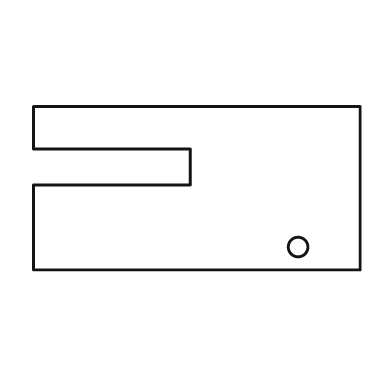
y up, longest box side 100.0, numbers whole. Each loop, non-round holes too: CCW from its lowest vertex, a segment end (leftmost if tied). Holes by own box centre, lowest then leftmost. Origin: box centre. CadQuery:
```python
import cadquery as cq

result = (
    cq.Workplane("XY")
    .moveTo(-50.0, -25.0)
    .lineTo(50.0, -25.0)
    .lineTo(50.0, 25.0)
    .lineTo(-50.0, 25.0)
    .lineTo(-50.0, 12.0)
    .lineTo(-2.0, 12.0)
    .lineTo(-2.0, 1.0)
    .lineTo(-50.0, 1.0)
    .close()
    .moveTo(31.0, -18.0)
    .circle(3.0)
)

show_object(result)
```